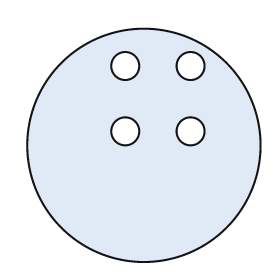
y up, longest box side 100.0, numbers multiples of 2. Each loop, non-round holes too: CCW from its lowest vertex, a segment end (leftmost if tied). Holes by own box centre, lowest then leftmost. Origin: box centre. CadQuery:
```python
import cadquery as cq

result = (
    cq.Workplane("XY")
    .moveTo(0.0, 0.0)
    .circle(50.0)
    .moveTo(-8.0, 6.0)
    .circle(6.0)
    .moveTo(20.0, 6.0)
    .circle(6.0)
    .moveTo(-8.0, 34.0)
    .circle(6.0)
    .moveTo(20.0, 34.0)
    .circle(6.0)
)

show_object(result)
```